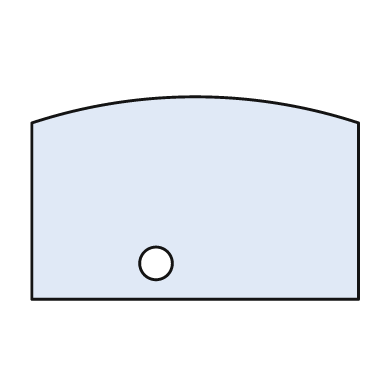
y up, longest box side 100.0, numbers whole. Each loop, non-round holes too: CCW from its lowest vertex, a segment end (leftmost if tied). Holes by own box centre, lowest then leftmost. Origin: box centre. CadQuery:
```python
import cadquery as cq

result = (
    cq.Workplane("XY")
    .moveTo(-50.0, -31.0)
    .lineTo(50.0, -31.0)
    .lineTo(50.0, 23.0)
    .threePointArc((0.0, 31.0), (-50.0, 23.0))
    .close()
    .moveTo(-12.0, -20.0)
    .circle(5.0)
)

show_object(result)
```